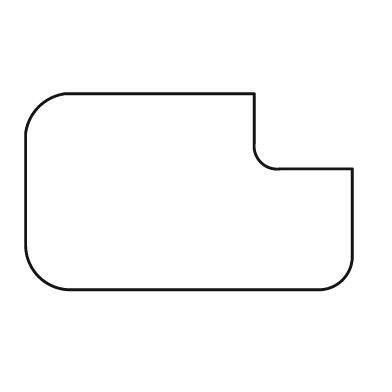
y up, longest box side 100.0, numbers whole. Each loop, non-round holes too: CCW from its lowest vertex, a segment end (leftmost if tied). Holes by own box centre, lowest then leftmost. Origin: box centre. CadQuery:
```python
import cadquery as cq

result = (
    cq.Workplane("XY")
    .moveTo(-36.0, -30.0)
    .lineTo(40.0, -30.0)
    .threePointArc((47.0, -27.0), (50.0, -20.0))
    .lineTo(50.0, 7.0)
    .lineTo(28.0, 7.0)
    .threePointArc((22.0, 9.0), (20.0, 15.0))
    .lineTo(20.0, 30.0)
    .lineTo(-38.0, 30.0)
    .threePointArc((-46.0, 26.0), (-50.0, 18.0))
    .lineTo(-50.0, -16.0)
    .threePointArc((-46.0, -26.0), (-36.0, -30.0))
    .close()
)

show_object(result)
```